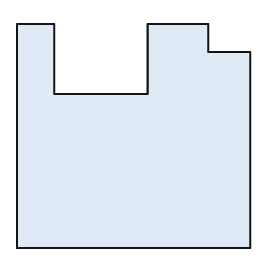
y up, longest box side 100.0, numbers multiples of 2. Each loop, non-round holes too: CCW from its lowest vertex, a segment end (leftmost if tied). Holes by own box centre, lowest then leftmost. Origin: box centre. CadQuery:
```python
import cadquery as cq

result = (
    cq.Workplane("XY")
    .moveTo(-50.0, -48.0)
    .lineTo(50.0, -48.0)
    .lineTo(50.0, 36.0)
    .lineTo(32.0, 36.0)
    .lineTo(32.0, 48.0)
    .lineTo(6.0, 48.0)
    .lineTo(6.0, 18.0)
    .lineTo(-34.0, 18.0)
    .lineTo(-34.0, 48.0)
    .lineTo(-50.0, 48.0)
    .close()
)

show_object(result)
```